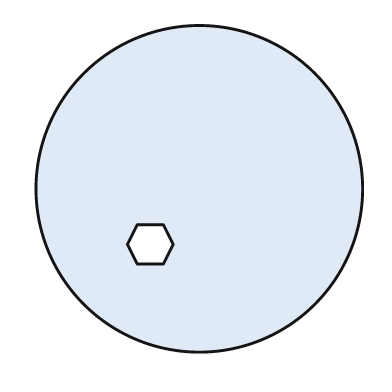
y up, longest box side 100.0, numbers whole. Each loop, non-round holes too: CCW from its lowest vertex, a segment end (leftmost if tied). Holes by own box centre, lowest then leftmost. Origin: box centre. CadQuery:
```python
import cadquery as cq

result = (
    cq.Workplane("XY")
    .moveTo(0.0, 0.0)
    .circle(50.0)
    .moveTo(-19.0, -23.0)
    .lineTo(-11.0, -23.0)
    .lineTo(-8.0, -17.0)
    .lineTo(-11.0, -11.0)
    .lineTo(-19.0, -11.0)
    .lineTo(-22.0, -17.0)
    .close()
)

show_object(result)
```